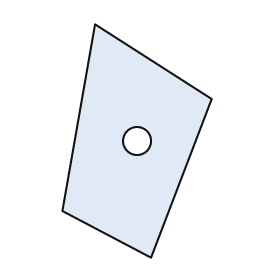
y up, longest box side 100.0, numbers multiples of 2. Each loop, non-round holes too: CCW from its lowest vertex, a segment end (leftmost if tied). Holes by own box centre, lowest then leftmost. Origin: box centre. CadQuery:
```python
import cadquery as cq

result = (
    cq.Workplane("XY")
    .moveTo(6.0, -50.0)
    .lineTo(32.0, 18.0)
    .lineTo(-18.0, 50.0)
    .lineTo(-32.0, -30.0)
    .close()
    .moveTo(0.0, 0.0)
    .circle(6.0)
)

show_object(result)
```